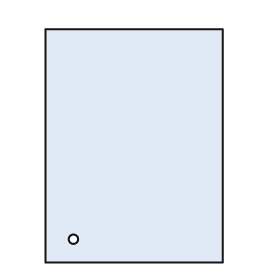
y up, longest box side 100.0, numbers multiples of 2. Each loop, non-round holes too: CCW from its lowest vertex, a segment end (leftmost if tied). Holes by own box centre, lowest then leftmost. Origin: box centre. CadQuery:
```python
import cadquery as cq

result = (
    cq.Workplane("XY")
    .moveTo(-38.0, -50.0)
    .lineTo(38.0, -50.0)
    .lineTo(38.0, 50.0)
    .lineTo(-38.0, 50.0)
    .close()
    .moveTo(-26.0, -40.0)
    .circle(2.0)
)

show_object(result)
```